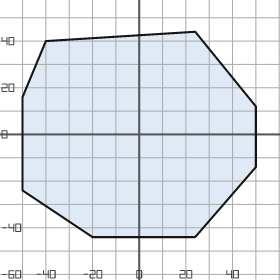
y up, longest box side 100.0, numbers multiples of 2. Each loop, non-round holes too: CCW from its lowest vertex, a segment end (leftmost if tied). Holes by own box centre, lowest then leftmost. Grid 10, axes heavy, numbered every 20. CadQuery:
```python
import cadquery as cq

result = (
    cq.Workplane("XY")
    .moveTo(-20.0, -44.0)
    .lineTo(24.0, -44.0)
    .lineTo(50.0, -14.0)
    .lineTo(50.0, 12.0)
    .lineTo(24.0, 44.0)
    .lineTo(-40.0, 40.0)
    .lineTo(-50.0, 16.0)
    .lineTo(-50.0, -24.0)
    .close()
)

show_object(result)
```